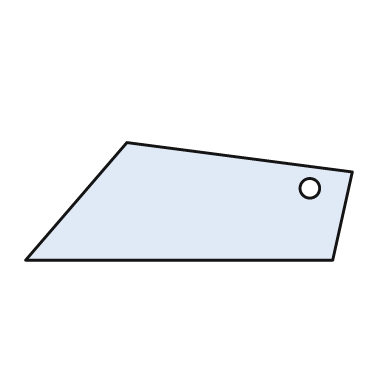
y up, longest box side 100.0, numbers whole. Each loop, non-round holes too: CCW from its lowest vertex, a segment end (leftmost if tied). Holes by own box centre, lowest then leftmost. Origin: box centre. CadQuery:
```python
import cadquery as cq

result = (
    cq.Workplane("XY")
    .moveTo(-50.0, -18.0)
    .lineTo(44.0, -18.0)
    .lineTo(50.0, 9.0)
    .lineTo(-19.0, 18.0)
    .close()
    .moveTo(37.0, 4.0)
    .circle(3.0)
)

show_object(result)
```